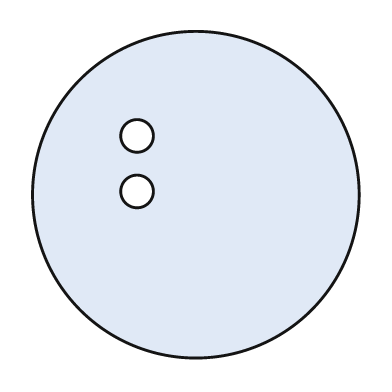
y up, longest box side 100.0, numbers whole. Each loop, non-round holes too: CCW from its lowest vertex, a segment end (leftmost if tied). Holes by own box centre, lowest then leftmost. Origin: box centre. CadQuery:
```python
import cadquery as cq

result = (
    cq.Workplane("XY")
    .moveTo(0.0, 0.0)
    .circle(50.0)
    .moveTo(-18.0, 1.0)
    .circle(5.0)
    .moveTo(-18.0, 18.0)
    .circle(5.0)
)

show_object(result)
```